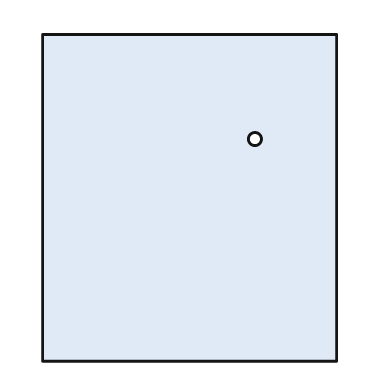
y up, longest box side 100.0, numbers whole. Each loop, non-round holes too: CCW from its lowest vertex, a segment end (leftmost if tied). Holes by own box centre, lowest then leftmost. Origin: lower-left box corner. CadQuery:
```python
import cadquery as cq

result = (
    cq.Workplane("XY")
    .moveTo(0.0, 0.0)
    .lineTo(90.0, 0.0)
    .lineTo(90.0, 100.0)
    .lineTo(0.0, 100.0)
    .close()
    .moveTo(65.0, 68.0)
    .circle(2.0)
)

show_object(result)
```